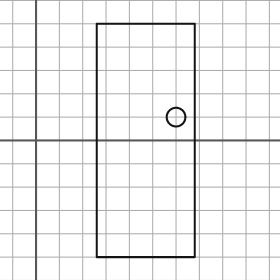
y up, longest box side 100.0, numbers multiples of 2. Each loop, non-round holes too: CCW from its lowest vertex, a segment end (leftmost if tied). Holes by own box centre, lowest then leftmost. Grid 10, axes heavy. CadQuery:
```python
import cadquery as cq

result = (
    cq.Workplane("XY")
    .moveTo(26.0, -50.0)
    .lineTo(68.0, -50.0)
    .lineTo(68.0, 50.0)
    .lineTo(26.0, 50.0)
    .close()
    .moveTo(60.0, 10.0)
    .circle(4.0)
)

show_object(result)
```